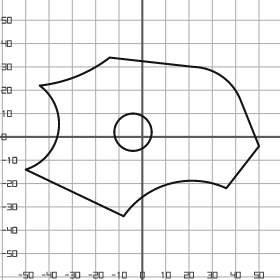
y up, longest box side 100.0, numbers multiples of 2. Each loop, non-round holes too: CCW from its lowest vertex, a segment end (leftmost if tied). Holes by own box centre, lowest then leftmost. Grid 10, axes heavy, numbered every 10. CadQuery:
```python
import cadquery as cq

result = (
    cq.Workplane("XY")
    .moveTo(-8.0, -34.0)
    .threePointArc((12.0, -20.0), (36.0, -22.0))
    .lineTo(50.0, -4.0)
    .lineTo(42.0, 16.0)
    .threePointArc((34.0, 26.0), (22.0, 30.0))
    .lineTo(-14.0, 34.0)
    .threePointArc((-28.0, 26.0), (-44.0, 22.0))
    .threePointArc((-36.0, 2.0), (-50.0, -14.0))
    .close()
    .moveTo(-4.0, 2.0)
    .circle(8.0)
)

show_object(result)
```